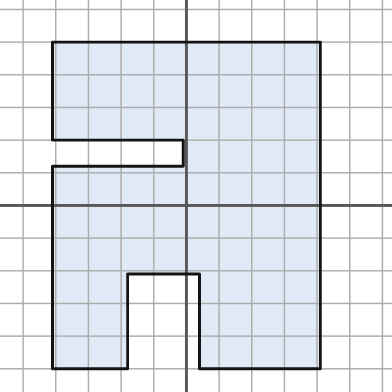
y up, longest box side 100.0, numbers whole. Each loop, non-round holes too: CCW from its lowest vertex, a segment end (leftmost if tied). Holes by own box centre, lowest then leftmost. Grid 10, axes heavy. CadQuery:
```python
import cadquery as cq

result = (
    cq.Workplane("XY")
    .moveTo(-41.0, -50.0)
    .lineTo(-18.0, -50.0)
    .lineTo(-18.0, -21.0)
    .lineTo(4.0, -21.0)
    .lineTo(4.0, -50.0)
    .lineTo(41.0, -50.0)
    .lineTo(41.0, 50.0)
    .lineTo(-41.0, 50.0)
    .lineTo(-41.0, 20.0)
    .lineTo(-1.0, 20.0)
    .lineTo(-1.0, 12.0)
    .lineTo(-41.0, 12.0)
    .close()
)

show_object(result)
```